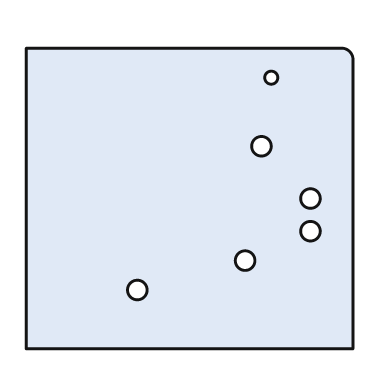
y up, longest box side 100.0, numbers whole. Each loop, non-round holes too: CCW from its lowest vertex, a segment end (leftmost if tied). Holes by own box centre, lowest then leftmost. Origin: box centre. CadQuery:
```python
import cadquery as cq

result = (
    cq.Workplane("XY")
    .moveTo(-50.0, -46.0)
    .lineTo(50.0, -46.0)
    .lineTo(50.0, 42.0)
    .threePointArc((49.0, 45.0), (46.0, 46.0))
    .lineTo(-50.0, 46.0)
    .close()
    .moveTo(-16.0, -28.0)
    .circle(3.0)
    .moveTo(17.0, -19.0)
    .circle(3.0)
    .moveTo(37.0, -10.0)
    .circle(3.0)
    .moveTo(37.0, 0.0)
    .circle(3.0)
    .moveTo(22.0, 16.0)
    .circle(3.0)
    .moveTo(25.0, 37.0)
    .circle(2.0)
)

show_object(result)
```